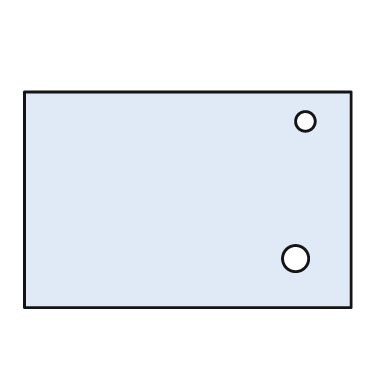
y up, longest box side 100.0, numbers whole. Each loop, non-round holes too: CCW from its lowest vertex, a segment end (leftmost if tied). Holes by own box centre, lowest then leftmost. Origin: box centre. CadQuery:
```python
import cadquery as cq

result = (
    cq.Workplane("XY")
    .moveTo(-50.0, -33.0)
    .lineTo(50.0, -33.0)
    .lineTo(50.0, 33.0)
    .lineTo(-50.0, 33.0)
    .close()
    .moveTo(33.0, -18.0)
    .circle(4.0)
    .moveTo(36.0, 24.0)
    .circle(3.0)
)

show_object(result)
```